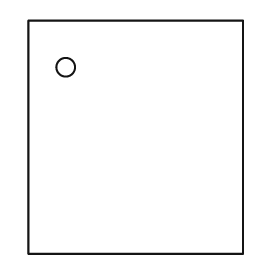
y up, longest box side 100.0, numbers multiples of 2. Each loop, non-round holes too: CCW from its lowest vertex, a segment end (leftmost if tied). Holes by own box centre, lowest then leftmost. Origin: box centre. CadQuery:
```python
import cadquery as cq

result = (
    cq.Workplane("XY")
    .moveTo(-46.0, -50.0)
    .lineTo(46.0, -50.0)
    .lineTo(46.0, 50.0)
    .lineTo(-46.0, 50.0)
    .close()
    .moveTo(-30.0, 30.0)
    .circle(4.0)
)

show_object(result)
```